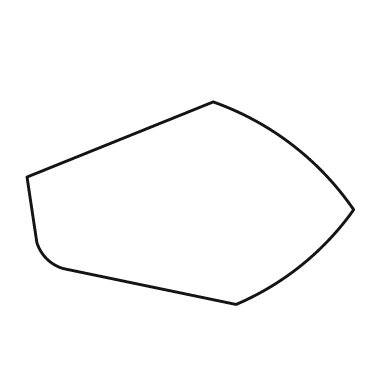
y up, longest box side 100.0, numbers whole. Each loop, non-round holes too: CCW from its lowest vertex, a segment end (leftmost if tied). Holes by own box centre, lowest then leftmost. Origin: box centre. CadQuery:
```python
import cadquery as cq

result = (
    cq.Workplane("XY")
    .moveTo(14.0, -31.0)
    .threePointArc((34.0, -19.0), (50.0, -2.0))
    .threePointArc((31.0, 18.0), (7.0, 31.0))
    .lineTo(-50.0, 8.0)
    .lineTo(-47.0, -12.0)
    .threePointArc((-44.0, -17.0), (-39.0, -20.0))
    .close()
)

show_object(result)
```